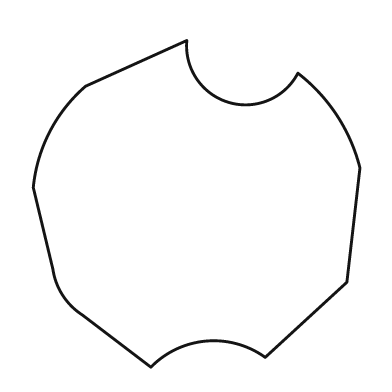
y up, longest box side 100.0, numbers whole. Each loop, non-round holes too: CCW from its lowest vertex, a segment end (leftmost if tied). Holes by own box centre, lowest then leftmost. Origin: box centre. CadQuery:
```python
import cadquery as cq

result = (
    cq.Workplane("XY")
    .moveTo(-14.0, -50.0)
    .threePointArc((3.0, -42.0), (21.0, -47.0))
    .lineTo(46.0, -24.0)
    .lineTo(50.0, 11.0)
    .threePointArc((43.0, 27.0), (31.0, 40.0))
    .threePointArc((10.0, 31.0), (-3.0, 50.0))
    .lineTo(-34.0, 36.0)
    .threePointArc((-45.0, 22.0), (-50.0, 5.0))
    .lineTo(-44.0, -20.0)
    .threePointArc((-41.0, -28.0), (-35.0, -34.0))
    .close()
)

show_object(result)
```